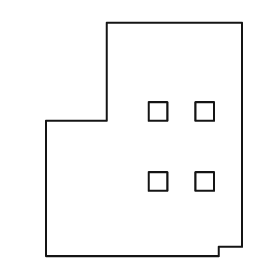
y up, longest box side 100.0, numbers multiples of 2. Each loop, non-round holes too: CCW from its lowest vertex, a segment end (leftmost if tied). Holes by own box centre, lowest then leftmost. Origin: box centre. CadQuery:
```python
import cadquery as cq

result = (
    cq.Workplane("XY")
    .moveTo(-42.0, -50.0)
    .lineTo(32.0, -50.0)
    .lineTo(32.0, -46.0)
    .lineTo(42.0, -46.0)
    .lineTo(42.0, 50.0)
    .lineTo(-16.0, 50.0)
    .lineTo(-16.0, 8.0)
    .lineTo(-42.0, 8.0)
    .close()
    .moveTo(2.0, -22.0)
    .lineTo(10.0, -22.0)
    .lineTo(10.0, -14.0)
    .lineTo(2.0, -14.0)
    .close()
    .moveTo(22.0, -22.0)
    .lineTo(30.0, -22.0)
    .lineTo(30.0, -14.0)
    .lineTo(22.0, -14.0)
    .close()
    .moveTo(2.0, 8.0)
    .lineTo(10.0, 8.0)
    .lineTo(10.0, 16.0)
    .lineTo(2.0, 16.0)
    .close()
    .moveTo(22.0, 8.0)
    .lineTo(30.0, 8.0)
    .lineTo(30.0, 16.0)
    .lineTo(22.0, 16.0)
    .close()
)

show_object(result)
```